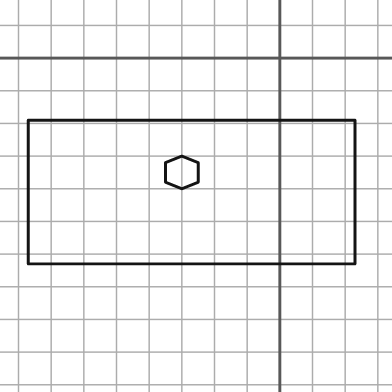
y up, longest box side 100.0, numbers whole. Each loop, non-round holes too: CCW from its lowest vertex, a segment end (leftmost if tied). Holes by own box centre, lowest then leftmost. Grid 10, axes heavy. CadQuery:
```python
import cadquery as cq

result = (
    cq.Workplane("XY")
    .moveTo(-77.0, -63.0)
    .lineTo(23.0, -63.0)
    .lineTo(23.0, -19.0)
    .lineTo(-77.0, -19.0)
    .close()
    .moveTo(-30.0, -40.0)
    .lineTo(-25.0, -38.0)
    .lineTo(-25.0, -32.0)
    .lineTo(-30.0, -30.0)
    .lineTo(-35.0, -32.0)
    .lineTo(-35.0, -38.0)
    .close()
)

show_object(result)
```